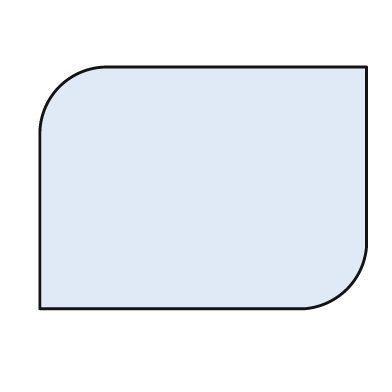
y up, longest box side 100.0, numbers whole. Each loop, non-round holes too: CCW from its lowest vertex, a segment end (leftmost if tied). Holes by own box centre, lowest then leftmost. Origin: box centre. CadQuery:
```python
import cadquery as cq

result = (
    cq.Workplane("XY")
    .moveTo(-50.0, -37.0)
    .lineTo(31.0, -37.0)
    .threePointArc((44.0, -31.0), (50.0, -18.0))
    .lineTo(50.0, 37.0)
    .lineTo(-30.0, 37.0)
    .threePointArc((-44.0, 31.0), (-50.0, 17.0))
    .close()
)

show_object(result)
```